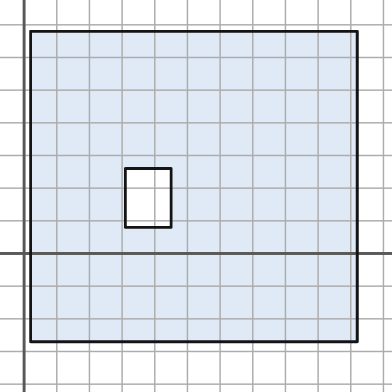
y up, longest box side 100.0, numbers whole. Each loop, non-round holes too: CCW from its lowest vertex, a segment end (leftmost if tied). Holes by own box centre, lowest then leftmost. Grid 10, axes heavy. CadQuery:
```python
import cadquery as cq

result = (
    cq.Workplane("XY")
    .moveTo(2.0, -27.0)
    .lineTo(102.0, -27.0)
    .lineTo(102.0, 68.0)
    .lineTo(2.0, 68.0)
    .close()
    .moveTo(31.0, 8.0)
    .lineTo(45.0, 8.0)
    .lineTo(45.0, 26.0)
    .lineTo(31.0, 26.0)
    .close()
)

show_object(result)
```